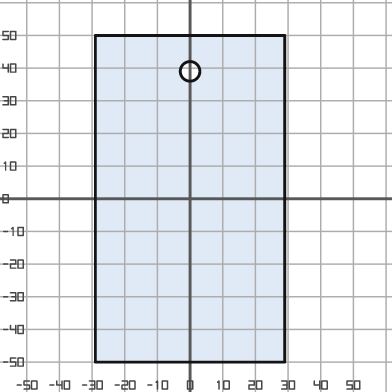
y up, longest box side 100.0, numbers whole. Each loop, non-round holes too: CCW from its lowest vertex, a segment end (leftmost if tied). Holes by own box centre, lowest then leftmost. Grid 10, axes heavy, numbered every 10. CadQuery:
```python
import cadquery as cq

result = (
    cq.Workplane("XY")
    .moveTo(-29.0, -50.0)
    .lineTo(29.0, -50.0)
    .lineTo(29.0, 50.0)
    .lineTo(-29.0, 50.0)
    .close()
    .moveTo(0.0, 39.0)
    .circle(3.0)
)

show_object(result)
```